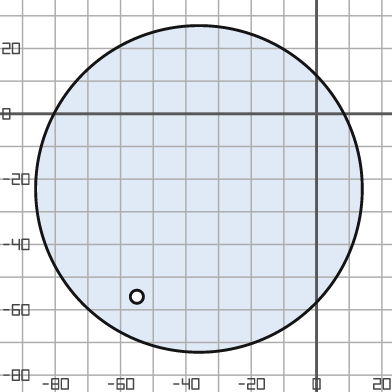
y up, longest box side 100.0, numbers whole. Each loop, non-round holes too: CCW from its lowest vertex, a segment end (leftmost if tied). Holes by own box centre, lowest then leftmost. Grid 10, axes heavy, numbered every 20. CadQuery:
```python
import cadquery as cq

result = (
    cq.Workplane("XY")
    .moveTo(-36.0, -23.0)
    .circle(50.0)
    .moveTo(-55.0, -56.0)
    .circle(2.0)
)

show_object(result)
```